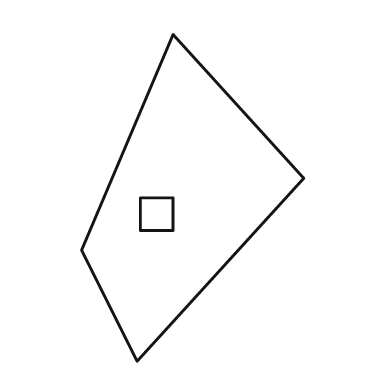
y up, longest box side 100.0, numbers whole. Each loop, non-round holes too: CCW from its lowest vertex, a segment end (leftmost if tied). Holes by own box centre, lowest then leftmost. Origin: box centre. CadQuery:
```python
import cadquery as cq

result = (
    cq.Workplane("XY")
    .moveTo(-17.0, -50.0)
    .lineTo(34.0, 6.0)
    .lineTo(-6.0, 50.0)
    .lineTo(-34.0, -16.0)
    .close()
    .moveTo(-16.0, -10.0)
    .lineTo(-6.0, -10.0)
    .lineTo(-6.0, 0.0)
    .lineTo(-16.0, 0.0)
    .close()
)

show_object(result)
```